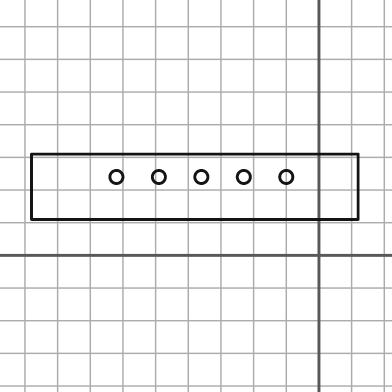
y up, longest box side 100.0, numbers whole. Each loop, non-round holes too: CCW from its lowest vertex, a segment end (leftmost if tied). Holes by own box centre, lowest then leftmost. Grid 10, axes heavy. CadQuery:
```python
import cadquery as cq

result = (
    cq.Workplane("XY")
    .moveTo(-88.0, 11.0)
    .lineTo(12.0, 11.0)
    .lineTo(12.0, 31.0)
    .lineTo(-88.0, 31.0)
    .close()
    .moveTo(-62.0, 24.0)
    .circle(2.0)
    .moveTo(-49.0, 24.0)
    .circle(2.0)
    .moveTo(-36.0, 24.0)
    .circle(2.0)
    .moveTo(-23.0, 24.0)
    .circle(2.0)
    .moveTo(-10.0, 24.0)
    .circle(2.0)
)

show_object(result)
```